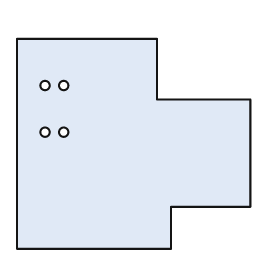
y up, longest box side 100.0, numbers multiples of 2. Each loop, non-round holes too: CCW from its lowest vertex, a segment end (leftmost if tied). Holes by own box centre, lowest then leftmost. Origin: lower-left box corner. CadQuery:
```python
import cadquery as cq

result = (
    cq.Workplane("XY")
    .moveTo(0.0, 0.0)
    .lineTo(66.0, 0.0)
    .lineTo(66.0, 18.0)
    .lineTo(100.0, 18.0)
    .lineTo(100.0, 64.0)
    .lineTo(60.0, 64.0)
    .lineTo(60.0, 90.0)
    .lineTo(0.0, 90.0)
    .close()
    .moveTo(12.0, 50.0)
    .circle(2.0)
    .moveTo(20.0, 50.0)
    .circle(2.0)
    .moveTo(12.0, 70.0)
    .circle(2.0)
    .moveTo(20.0, 70.0)
    .circle(2.0)
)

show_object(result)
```